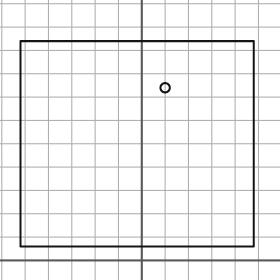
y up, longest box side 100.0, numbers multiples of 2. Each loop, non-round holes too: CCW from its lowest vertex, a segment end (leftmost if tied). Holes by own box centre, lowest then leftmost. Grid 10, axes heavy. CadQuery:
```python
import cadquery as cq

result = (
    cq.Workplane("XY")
    .moveTo(-52.0, 6.0)
    .lineTo(48.0, 6.0)
    .lineTo(48.0, 94.0)
    .lineTo(-52.0, 94.0)
    .close()
    .moveTo(10.0, 74.0)
    .circle(2.0)
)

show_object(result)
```